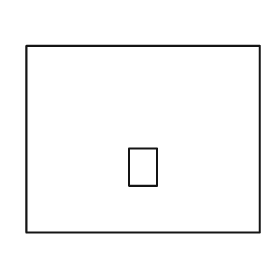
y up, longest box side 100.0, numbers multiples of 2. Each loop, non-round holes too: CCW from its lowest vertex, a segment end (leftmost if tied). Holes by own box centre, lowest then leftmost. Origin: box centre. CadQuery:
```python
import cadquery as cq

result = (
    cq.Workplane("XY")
    .moveTo(-50.0, -40.0)
    .lineTo(50.0, -40.0)
    .lineTo(50.0, 40.0)
    .lineTo(-50.0, 40.0)
    .close()
    .moveTo(-6.0, -20.0)
    .lineTo(6.0, -20.0)
    .lineTo(6.0, -4.0)
    .lineTo(-6.0, -4.0)
    .close()
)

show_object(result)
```